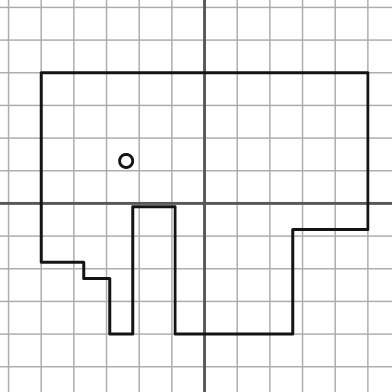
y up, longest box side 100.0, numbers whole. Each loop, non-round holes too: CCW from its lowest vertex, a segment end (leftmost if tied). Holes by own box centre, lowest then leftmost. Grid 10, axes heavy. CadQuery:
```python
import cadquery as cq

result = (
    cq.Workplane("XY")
    .moveTo(-29.0, -40.0)
    .lineTo(-22.0, -40.0)
    .lineTo(-22.0, -1.0)
    .lineTo(-9.0, -1.0)
    .lineTo(-9.0, -40.0)
    .lineTo(27.0, -40.0)
    .lineTo(27.0, -8.0)
    .lineTo(50.0, -8.0)
    .lineTo(50.0, 40.0)
    .lineTo(-50.0, 40.0)
    .lineTo(-50.0, -18.0)
    .lineTo(-37.0, -18.0)
    .lineTo(-37.0, -23.0)
    .lineTo(-29.0, -23.0)
    .close()
    .moveTo(-24.0, 13.0)
    .circle(2.0)
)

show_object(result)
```